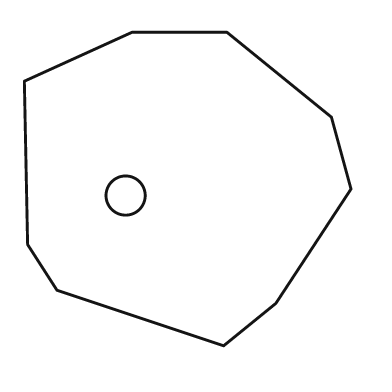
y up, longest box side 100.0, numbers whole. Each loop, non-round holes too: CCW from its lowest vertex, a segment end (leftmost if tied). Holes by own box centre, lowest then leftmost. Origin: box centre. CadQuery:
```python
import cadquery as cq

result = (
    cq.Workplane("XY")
    .moveTo(11.0, -48.0)
    .lineTo(27.0, -35.0)
    .lineTo(50.0, 0.0)
    .lineTo(44.0, 22.0)
    .lineTo(12.0, 48.0)
    .lineTo(-17.0, 48.0)
    .lineTo(-50.0, 33.0)
    .lineTo(-49.0, -17.0)
    .lineTo(-40.0, -31.0)
    .close()
    .moveTo(-19.0, -2.0)
    .circle(6.0)
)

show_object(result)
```